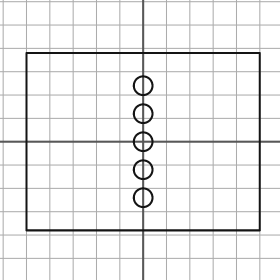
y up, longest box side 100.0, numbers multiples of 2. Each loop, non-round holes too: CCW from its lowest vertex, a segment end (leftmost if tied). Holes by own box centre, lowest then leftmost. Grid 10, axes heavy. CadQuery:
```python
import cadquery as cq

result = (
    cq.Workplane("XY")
    .moveTo(-50.0, -38.0)
    .lineTo(50.0, -38.0)
    .lineTo(50.0, 38.0)
    .lineTo(-50.0, 38.0)
    .close()
    .moveTo(0.0, -24.0)
    .circle(4.0)
    .moveTo(0.0, -12.0)
    .circle(4.0)
    .moveTo(0.0, 0.0)
    .circle(4.0)
    .moveTo(0.0, 12.0)
    .circle(4.0)
    .moveTo(0.0, 24.0)
    .circle(4.0)
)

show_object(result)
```